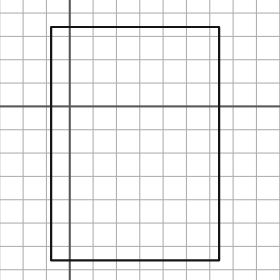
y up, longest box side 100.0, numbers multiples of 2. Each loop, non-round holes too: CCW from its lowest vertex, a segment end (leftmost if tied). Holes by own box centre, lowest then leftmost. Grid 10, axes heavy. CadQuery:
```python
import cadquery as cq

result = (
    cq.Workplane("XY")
    .moveTo(-8.0, -66.0)
    .lineTo(64.0, -66.0)
    .lineTo(64.0, 34.0)
    .lineTo(-8.0, 34.0)
    .close()
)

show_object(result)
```